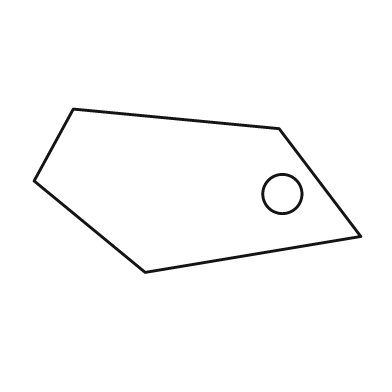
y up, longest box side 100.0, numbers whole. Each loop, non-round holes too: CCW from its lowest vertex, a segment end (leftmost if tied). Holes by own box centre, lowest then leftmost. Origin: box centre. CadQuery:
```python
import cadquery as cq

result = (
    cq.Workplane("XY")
    .moveTo(-16.0, -25.0)
    .lineTo(50.0, -14.0)
    .lineTo(25.0, 19.0)
    .lineTo(-38.0, 25.0)
    .lineTo(-50.0, 3.0)
    .close()
    .moveTo(26.0, -1.0)
    .circle(6.0)
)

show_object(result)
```